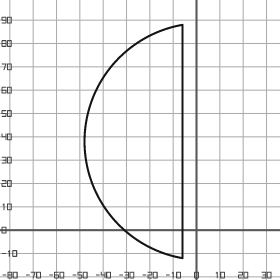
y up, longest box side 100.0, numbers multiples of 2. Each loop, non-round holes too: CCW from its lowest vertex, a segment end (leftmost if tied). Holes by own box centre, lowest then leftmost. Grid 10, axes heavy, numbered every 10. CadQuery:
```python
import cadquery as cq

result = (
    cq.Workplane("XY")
    .moveTo(-6.0, -12.0)
    .lineTo(-6.0, 88.0)
    .threePointArc((-48.0, 38.0), (-6.0, -12.0))
    .close()
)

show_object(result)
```